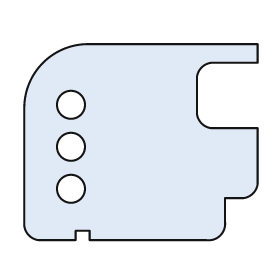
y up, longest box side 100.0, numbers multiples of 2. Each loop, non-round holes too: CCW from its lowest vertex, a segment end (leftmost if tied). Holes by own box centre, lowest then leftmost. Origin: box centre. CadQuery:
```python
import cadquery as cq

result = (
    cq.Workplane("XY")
    .moveTo(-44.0, -42.0)
    .lineTo(-28.0, -42.0)
    .lineTo(-28.0, -38.0)
    .lineTo(-22.0, -38.0)
    .lineTo(-22.0, -42.0)
    .lineTo(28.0, -42.0)
    .threePointArc((34.0, -40.0), (36.0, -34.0))
    .lineTo(36.0, -24.0)
    .lineTo(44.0, -24.0)
    .threePointArc((48.0, -22.0), (50.0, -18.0))
    .lineTo(50.0, 6.0)
    .lineTo(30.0, 6.0)
    .threePointArc((26.0, 8.0), (24.0, 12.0))
    .lineTo(24.0, 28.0)
    .threePointArc((26.0, 32.0), (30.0, 34.0))
    .lineTo(50.0, 34.0)
    .lineTo(50.0, 42.0)
    .lineTo(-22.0, 42.0)
    .threePointArc((-42.0, 34.0), (-50.0, 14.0))
    .lineTo(-50.0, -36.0)
    .threePointArc((-48.0, -40.0), (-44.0, -42.0))
    .close()
    .moveTo(-30.0, -20.0)
    .circle(6.0)
    .moveTo(-30.0, -2.0)
    .circle(6.0)
    .moveTo(-30.0, 16.0)
    .circle(6.0)
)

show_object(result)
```